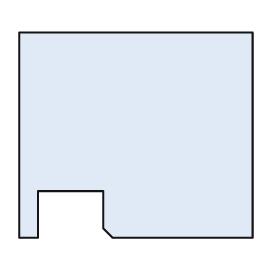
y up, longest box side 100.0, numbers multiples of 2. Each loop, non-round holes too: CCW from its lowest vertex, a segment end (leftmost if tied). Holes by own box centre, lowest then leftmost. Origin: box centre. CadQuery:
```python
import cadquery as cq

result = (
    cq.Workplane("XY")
    .moveTo(-50.0, -44.0)
    .lineTo(-42.0, -44.0)
    .lineTo(-42.0, -24.0)
    .lineTo(-14.0, -24.0)
    .lineTo(-14.0, -40.0)
    .lineTo(-10.0, -44.0)
    .lineTo(50.0, -44.0)
    .lineTo(50.0, 44.0)
    .lineTo(-50.0, 44.0)
    .close()
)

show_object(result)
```